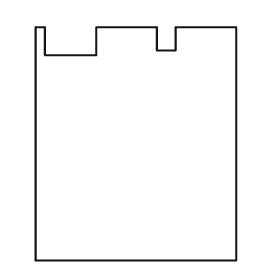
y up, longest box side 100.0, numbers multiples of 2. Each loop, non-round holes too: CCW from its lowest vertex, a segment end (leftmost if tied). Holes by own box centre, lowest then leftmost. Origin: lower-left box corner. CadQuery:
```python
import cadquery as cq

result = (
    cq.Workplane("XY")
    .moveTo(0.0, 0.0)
    .lineTo(86.0, 0.0)
    .lineTo(86.0, 100.0)
    .lineTo(60.0, 100.0)
    .lineTo(60.0, 90.0)
    .lineTo(52.0, 90.0)
    .lineTo(52.0, 100.0)
    .lineTo(26.0, 100.0)
    .lineTo(26.0, 88.0)
    .lineTo(4.0, 88.0)
    .lineTo(4.0, 100.0)
    .lineTo(0.0, 100.0)
    .close()
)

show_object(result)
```